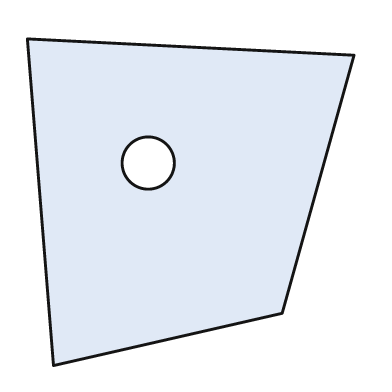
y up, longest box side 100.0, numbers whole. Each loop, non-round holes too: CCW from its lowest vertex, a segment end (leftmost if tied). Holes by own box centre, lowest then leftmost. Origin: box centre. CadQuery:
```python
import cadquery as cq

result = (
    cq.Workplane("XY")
    .moveTo(-42.0, -50.0)
    .lineTo(28.0, -34.0)
    .lineTo(50.0, 45.0)
    .lineTo(-50.0, 50.0)
    .close()
    .moveTo(-13.0, 12.0)
    .circle(8.0)
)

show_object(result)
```